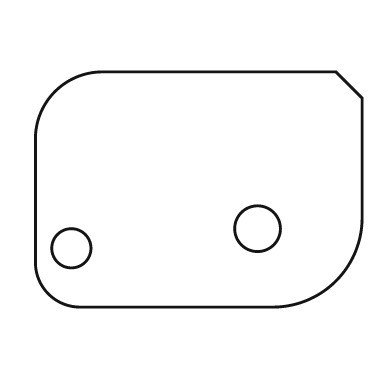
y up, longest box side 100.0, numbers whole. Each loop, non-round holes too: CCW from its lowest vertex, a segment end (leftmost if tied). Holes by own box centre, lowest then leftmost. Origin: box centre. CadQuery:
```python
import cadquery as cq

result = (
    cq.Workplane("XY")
    .moveTo(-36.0, -36.0)
    .lineTo(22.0, -36.0)
    .threePointArc((42.0, -28.0), (50.0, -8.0))
    .lineTo(50.0, 28.0)
    .lineTo(42.0, 36.0)
    .lineTo(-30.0, 36.0)
    .threePointArc((-44.0, 30.0), (-50.0, 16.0))
    .lineTo(-50.0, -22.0)
    .threePointArc((-46.0, -32.0), (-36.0, -36.0))
    .close()
    .moveTo(-39.0, -18.0)
    .circle(6.0)
    .moveTo(18.0, -12.0)
    .circle(7.0)
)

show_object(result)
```